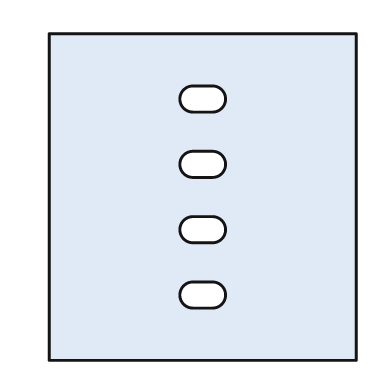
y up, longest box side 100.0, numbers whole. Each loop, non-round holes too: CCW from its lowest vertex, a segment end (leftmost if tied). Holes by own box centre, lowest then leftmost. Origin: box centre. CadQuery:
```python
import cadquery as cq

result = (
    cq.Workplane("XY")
    .moveTo(-47.0, -50.0)
    .lineTo(47.0, -50.0)
    .lineTo(47.0, 50.0)
    .lineTo(-47.0, 50.0)
    .close()
    .moveTo(-3.0, -34.0)
    .lineTo(3.0, -34.0)
    .threePointArc((7.0, -30.0), (3.0, -26.0))
    .lineTo(-3.0, -26.0)
    .threePointArc((-7.0, -30.0), (-3.0, -34.0))
    .close()
    .moveTo(-3.0, -14.0)
    .lineTo(3.0, -14.0)
    .threePointArc((7.0, -10.0), (3.0, -6.0))
    .lineTo(-3.0, -6.0)
    .threePointArc((-7.0, -10.0), (-3.0, -14.0))
    .close()
    .moveTo(-3.0, 6.0)
    .lineTo(3.0, 6.0)
    .threePointArc((7.0, 10.0), (3.0, 14.0))
    .lineTo(-3.0, 14.0)
    .threePointArc((-7.0, 10.0), (-3.0, 6.0))
    .close()
    .moveTo(-3.0, 26.0)
    .lineTo(3.0, 26.0)
    .threePointArc((7.0, 30.0), (3.0, 34.0))
    .lineTo(-3.0, 34.0)
    .threePointArc((-7.0, 30.0), (-3.0, 26.0))
    .close()
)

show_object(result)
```